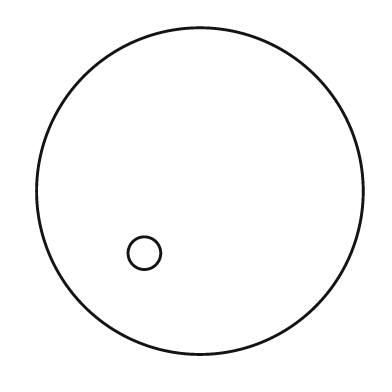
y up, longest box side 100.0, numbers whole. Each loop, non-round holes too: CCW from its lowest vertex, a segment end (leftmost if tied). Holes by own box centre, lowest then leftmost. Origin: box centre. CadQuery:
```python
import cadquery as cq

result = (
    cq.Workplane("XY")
    .moveTo(0.0, 0.0)
    .circle(50.0)
    .moveTo(-17.0, -19.0)
    .circle(5.0)
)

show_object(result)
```